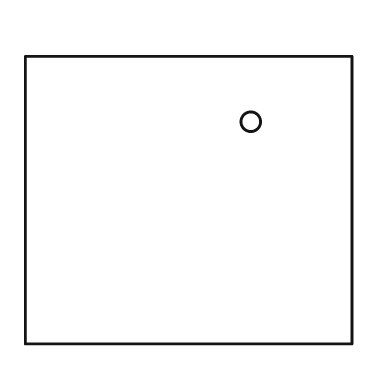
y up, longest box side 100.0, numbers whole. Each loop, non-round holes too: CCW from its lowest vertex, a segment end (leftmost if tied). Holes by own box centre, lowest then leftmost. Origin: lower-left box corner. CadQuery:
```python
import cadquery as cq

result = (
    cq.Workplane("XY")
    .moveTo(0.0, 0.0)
    .lineTo(100.0, 0.0)
    .lineTo(100.0, 88.0)
    .lineTo(0.0, 88.0)
    .close()
    .moveTo(69.0, 68.0)
    .circle(3.0)
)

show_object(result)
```